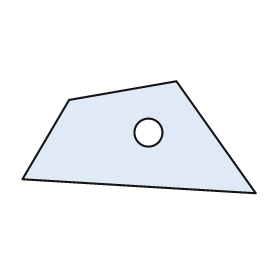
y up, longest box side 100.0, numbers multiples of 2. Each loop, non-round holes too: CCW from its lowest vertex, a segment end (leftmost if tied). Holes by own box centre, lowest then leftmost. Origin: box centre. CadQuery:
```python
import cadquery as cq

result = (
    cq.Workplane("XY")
    .moveTo(50.0, -24.0)
    .lineTo(16.0, 24.0)
    .lineTo(-30.0, 16.0)
    .lineTo(-50.0, -18.0)
    .close()
    .moveTo(4.0, 2.0)
    .circle(6.0)
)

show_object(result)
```